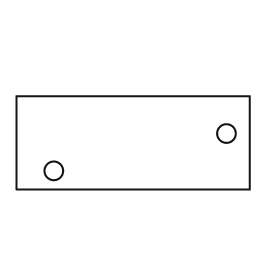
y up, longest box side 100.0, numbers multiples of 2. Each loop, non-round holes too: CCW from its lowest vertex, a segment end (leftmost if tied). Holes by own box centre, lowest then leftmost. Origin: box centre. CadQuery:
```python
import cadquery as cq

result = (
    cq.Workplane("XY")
    .moveTo(-50.0, -20.0)
    .lineTo(50.0, -20.0)
    .lineTo(50.0, 20.0)
    .lineTo(-50.0, 20.0)
    .close()
    .moveTo(-34.0, -12.0)
    .circle(4.0)
    .moveTo(40.0, 4.0)
    .circle(4.0)
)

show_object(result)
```